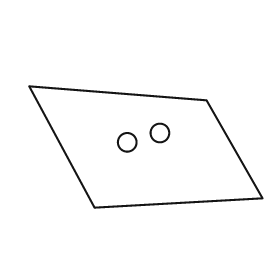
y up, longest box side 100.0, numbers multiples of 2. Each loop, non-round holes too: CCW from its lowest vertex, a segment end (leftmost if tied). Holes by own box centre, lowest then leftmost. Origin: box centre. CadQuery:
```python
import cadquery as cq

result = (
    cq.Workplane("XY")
    .moveTo(-22.0, -26.0)
    .lineTo(50.0, -22.0)
    .lineTo(26.0, 20.0)
    .lineTo(-50.0, 26.0)
    .close()
    .moveTo(-8.0, 2.0)
    .circle(4.0)
    .moveTo(6.0, 6.0)
    .circle(4.0)
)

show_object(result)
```